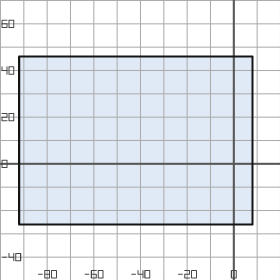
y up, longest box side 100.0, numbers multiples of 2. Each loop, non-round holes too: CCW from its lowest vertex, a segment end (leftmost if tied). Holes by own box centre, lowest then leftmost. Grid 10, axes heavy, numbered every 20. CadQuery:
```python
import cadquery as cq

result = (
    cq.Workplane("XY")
    .moveTo(-92.0, -26.0)
    .lineTo(8.0, -26.0)
    .lineTo(8.0, 46.0)
    .lineTo(-92.0, 46.0)
    .close()
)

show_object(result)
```